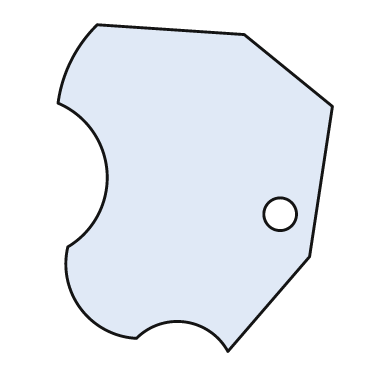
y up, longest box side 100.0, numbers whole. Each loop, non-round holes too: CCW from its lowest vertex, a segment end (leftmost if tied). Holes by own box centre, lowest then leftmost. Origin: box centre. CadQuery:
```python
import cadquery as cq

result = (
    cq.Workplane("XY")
    .moveTo(10.0, -50.0)
    .lineTo(35.0, -21.0)
    .lineTo(42.0, 25.0)
    .lineTo(15.0, 47.0)
    .lineTo(-30.0, 50.0)
    .threePointArc((-38.0, 39.0), (-42.0, 26.0))
    .threePointArc((-27.0, 5.0), (-39.0, -18.0))
    .threePointArc((-35.0, -37.0), (-18.0, -46.0))
    .threePointArc((-3.0, -41.0), (10.0, -50.0))
    .close()
    .moveTo(26.0, -8.0)
    .circle(5.0)
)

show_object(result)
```